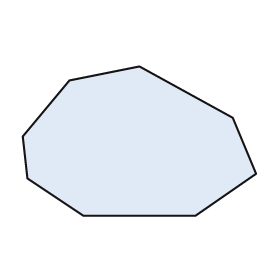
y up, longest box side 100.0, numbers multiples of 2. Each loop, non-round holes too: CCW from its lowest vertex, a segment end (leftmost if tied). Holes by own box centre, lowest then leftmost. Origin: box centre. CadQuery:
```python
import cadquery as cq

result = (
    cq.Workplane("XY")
    .moveTo(-24.0, -32.0)
    .lineTo(24.0, -32.0)
    .lineTo(50.0, -14.0)
    .lineTo(40.0, 10.0)
    .lineTo(0.0, 32.0)
    .lineTo(-30.0, 26.0)
    .lineTo(-50.0, 2.0)
    .lineTo(-48.0, -16.0)
    .close()
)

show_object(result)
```